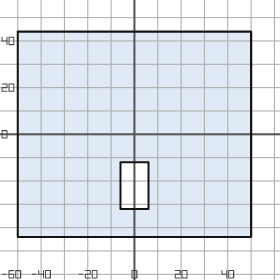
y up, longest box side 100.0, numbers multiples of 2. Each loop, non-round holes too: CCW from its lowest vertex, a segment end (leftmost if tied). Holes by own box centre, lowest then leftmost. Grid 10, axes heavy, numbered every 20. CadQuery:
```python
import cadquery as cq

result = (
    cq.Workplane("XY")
    .moveTo(-50.0, -44.0)
    .lineTo(50.0, -44.0)
    .lineTo(50.0, 44.0)
    .lineTo(-50.0, 44.0)
    .close()
    .moveTo(-6.0, -32.0)
    .lineTo(6.0, -32.0)
    .lineTo(6.0, -12.0)
    .lineTo(-6.0, -12.0)
    .close()
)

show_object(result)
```